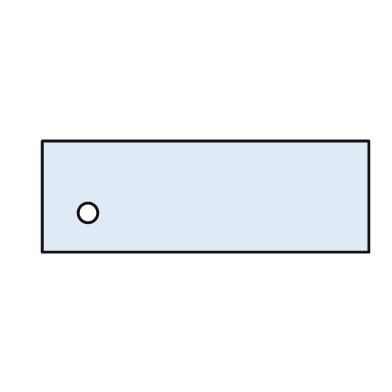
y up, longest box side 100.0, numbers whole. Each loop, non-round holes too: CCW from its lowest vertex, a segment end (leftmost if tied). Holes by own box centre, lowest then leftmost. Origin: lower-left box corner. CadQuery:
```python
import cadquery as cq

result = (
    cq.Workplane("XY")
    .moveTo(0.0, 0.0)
    .lineTo(100.0, 0.0)
    .lineTo(100.0, 34.0)
    .lineTo(0.0, 34.0)
    .close()
    .moveTo(14.0, 12.0)
    .circle(3.0)
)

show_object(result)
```